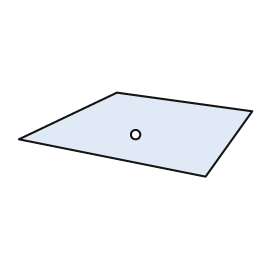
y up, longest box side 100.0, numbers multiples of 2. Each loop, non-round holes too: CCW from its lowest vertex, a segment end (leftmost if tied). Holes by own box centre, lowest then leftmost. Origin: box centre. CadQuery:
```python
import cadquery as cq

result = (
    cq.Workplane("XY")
    .moveTo(30.0, -18.0)
    .lineTo(50.0, 10.0)
    .lineTo(-8.0, 18.0)
    .lineTo(-50.0, -2.0)
    .close()
    .moveTo(0.0, 0.0)
    .circle(2.0)
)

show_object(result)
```